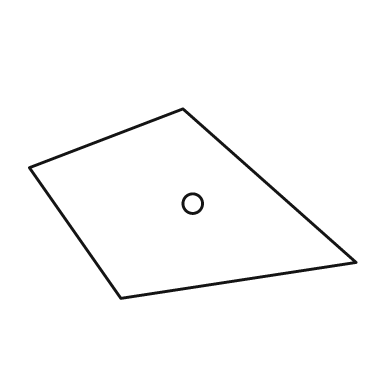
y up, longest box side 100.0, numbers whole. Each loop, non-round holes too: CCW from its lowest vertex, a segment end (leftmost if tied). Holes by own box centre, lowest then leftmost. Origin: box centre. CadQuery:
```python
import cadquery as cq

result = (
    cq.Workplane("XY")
    .moveTo(-22.0, -29.0)
    .lineTo(50.0, -18.0)
    .lineTo(-3.0, 29.0)
    .lineTo(-50.0, 11.0)
    .close()
    .moveTo(0.0, 0.0)
    .circle(3.0)
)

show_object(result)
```